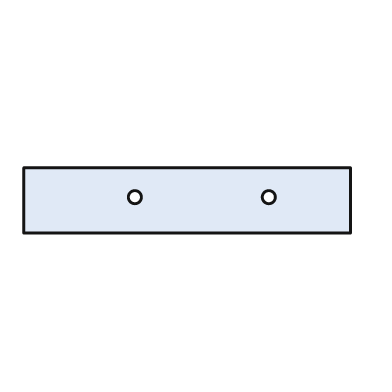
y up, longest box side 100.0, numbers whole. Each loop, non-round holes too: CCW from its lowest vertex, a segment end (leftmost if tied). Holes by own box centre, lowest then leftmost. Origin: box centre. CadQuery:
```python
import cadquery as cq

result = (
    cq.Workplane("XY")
    .moveTo(-50.0, -10.0)
    .lineTo(50.0, -10.0)
    .lineTo(50.0, 10.0)
    .lineTo(-50.0, 10.0)
    .close()
    .moveTo(-16.0, 1.0)
    .circle(2.0)
    .moveTo(25.0, 1.0)
    .circle(2.0)
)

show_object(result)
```